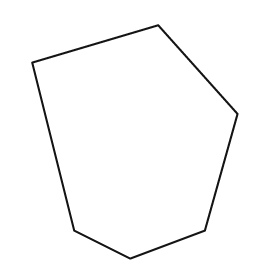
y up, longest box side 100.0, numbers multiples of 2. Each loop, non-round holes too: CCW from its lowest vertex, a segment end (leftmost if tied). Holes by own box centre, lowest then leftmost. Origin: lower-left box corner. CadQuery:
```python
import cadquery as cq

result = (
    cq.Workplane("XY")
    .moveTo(42.0, 0.0)
    .lineTo(74.0, 12.0)
    .lineTo(88.0, 62.0)
    .lineTo(54.0, 100.0)
    .lineTo(0.0, 84.0)
    .lineTo(18.0, 12.0)
    .close()
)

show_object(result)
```